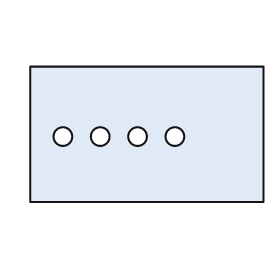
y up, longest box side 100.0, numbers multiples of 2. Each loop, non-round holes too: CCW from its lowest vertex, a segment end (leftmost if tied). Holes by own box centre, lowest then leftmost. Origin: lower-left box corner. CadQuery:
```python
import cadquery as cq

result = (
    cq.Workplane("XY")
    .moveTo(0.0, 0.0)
    .lineTo(100.0, 0.0)
    .lineTo(100.0, 58.0)
    .lineTo(0.0, 58.0)
    .close()
    .moveTo(14.0, 28.0)
    .circle(4.0)
    .moveTo(30.0, 28.0)
    .circle(4.0)
    .moveTo(46.0, 28.0)
    .circle(4.0)
    .moveTo(62.0, 28.0)
    .circle(4.0)
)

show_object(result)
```